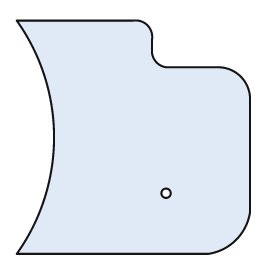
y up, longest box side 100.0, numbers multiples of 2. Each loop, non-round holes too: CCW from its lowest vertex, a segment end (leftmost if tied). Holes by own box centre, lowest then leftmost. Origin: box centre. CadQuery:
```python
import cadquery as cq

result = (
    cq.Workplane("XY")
    .moveTo(-50.0, -50.0)
    .lineTo(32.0, -50.0)
    .threePointArc((44.0, -44.0), (50.0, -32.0))
    .lineTo(50.0, 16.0)
    .threePointArc((46.0, 26.0), (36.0, 30.0))
    .lineTo(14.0, 30.0)
    .threePointArc((10.0, 32.0), (8.0, 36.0))
    .lineTo(8.0, 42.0)
    .threePointArc((6.0, 48.0), (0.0, 50.0))
    .lineTo(-50.0, 50.0)
    .threePointArc((-34.0, 0.0), (-50.0, -50.0))
    .close()
    .moveTo(14.0, -24.0)
    .circle(2.0)
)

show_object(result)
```